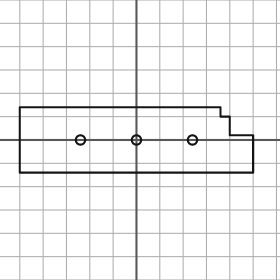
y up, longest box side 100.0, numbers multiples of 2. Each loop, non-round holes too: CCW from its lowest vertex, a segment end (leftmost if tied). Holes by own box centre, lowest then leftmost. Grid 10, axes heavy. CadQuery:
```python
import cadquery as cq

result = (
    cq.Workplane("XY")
    .moveTo(-50.0, -14.0)
    .lineTo(50.0, -14.0)
    .lineTo(50.0, 2.0)
    .lineTo(40.0, 2.0)
    .lineTo(40.0, 10.0)
    .lineTo(36.0, 10.0)
    .lineTo(36.0, 14.0)
    .lineTo(-50.0, 14.0)
    .close()
    .moveTo(-24.0, 0.0)
    .circle(2.0)
    .moveTo(0.0, 0.0)
    .circle(2.0)
    .moveTo(24.0, 0.0)
    .circle(2.0)
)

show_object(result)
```